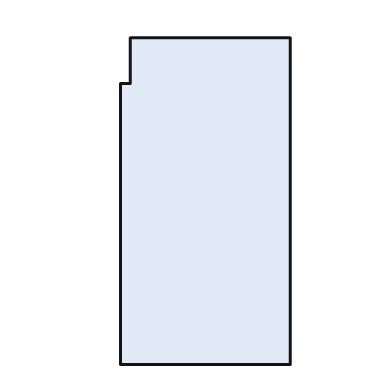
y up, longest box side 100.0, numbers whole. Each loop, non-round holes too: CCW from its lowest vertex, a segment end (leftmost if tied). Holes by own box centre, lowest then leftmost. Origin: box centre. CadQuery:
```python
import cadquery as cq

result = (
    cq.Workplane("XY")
    .moveTo(-26.0, -50.0)
    .lineTo(26.0, -50.0)
    .lineTo(26.0, 50.0)
    .lineTo(-23.0, 50.0)
    .lineTo(-23.0, 36.0)
    .lineTo(-26.0, 36.0)
    .close()
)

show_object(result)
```